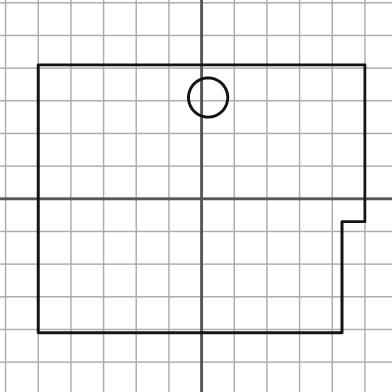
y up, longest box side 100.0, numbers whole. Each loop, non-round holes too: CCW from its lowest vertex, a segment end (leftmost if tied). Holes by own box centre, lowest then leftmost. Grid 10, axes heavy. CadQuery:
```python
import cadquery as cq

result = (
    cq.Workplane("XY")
    .moveTo(-50.0, -41.0)
    .lineTo(43.0, -41.0)
    .lineTo(43.0, -7.0)
    .lineTo(50.0, -7.0)
    .lineTo(50.0, 41.0)
    .lineTo(-50.0, 41.0)
    .close()
    .moveTo(2.0, 31.0)
    .circle(6.0)
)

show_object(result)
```